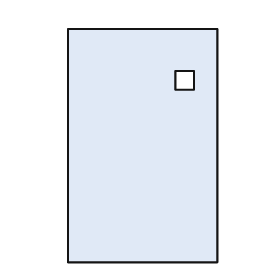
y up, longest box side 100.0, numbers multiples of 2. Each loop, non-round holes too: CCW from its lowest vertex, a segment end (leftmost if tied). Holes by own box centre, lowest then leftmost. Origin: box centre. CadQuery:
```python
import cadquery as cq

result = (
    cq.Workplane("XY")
    .moveTo(-32.0, -50.0)
    .lineTo(32.0, -50.0)
    .lineTo(32.0, 50.0)
    .lineTo(-32.0, 50.0)
    .close()
    .moveTo(14.0, 24.0)
    .lineTo(22.0, 24.0)
    .lineTo(22.0, 32.0)
    .lineTo(14.0, 32.0)
    .close()
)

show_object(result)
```